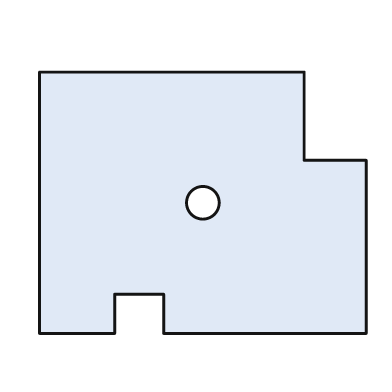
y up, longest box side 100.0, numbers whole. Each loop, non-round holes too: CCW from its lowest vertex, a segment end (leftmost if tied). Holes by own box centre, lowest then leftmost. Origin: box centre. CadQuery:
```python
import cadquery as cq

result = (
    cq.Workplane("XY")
    .moveTo(-50.0, -40.0)
    .lineTo(-27.0, -40.0)
    .lineTo(-27.0, -28.0)
    .lineTo(-12.0, -28.0)
    .lineTo(-12.0, -40.0)
    .lineTo(50.0, -40.0)
    .lineTo(50.0, 13.0)
    .lineTo(31.0, 13.0)
    .lineTo(31.0, 40.0)
    .lineTo(-50.0, 40.0)
    .close()
    .moveTo(0.0, 0.0)
    .circle(5.0)
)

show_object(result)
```